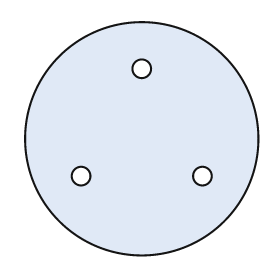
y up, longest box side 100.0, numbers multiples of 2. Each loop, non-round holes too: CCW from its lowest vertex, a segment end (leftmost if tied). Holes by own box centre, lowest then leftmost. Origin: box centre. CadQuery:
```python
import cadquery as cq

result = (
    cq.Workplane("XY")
    .moveTo(0.0, 0.0)
    .circle(50.0)
    .moveTo(-26.0, -16.0)
    .circle(4.0)
    .moveTo(26.0, -16.0)
    .circle(4.0)
    .moveTo(0.0, 30.0)
    .circle(4.0)
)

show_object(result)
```